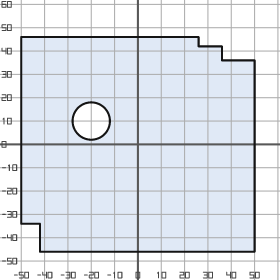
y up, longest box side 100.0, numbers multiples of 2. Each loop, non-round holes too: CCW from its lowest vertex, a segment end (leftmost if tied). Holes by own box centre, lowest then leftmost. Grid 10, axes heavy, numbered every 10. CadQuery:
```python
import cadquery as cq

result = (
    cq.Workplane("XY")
    .moveTo(-42.0, -46.0)
    .lineTo(50.0, -46.0)
    .lineTo(50.0, 36.0)
    .lineTo(36.0, 36.0)
    .lineTo(36.0, 42.0)
    .lineTo(26.0, 42.0)
    .lineTo(26.0, 46.0)
    .lineTo(-50.0, 46.0)
    .lineTo(-50.0, -34.0)
    .lineTo(-42.0, -34.0)
    .close()
    .moveTo(-20.0, 10.0)
    .circle(8.0)
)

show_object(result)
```